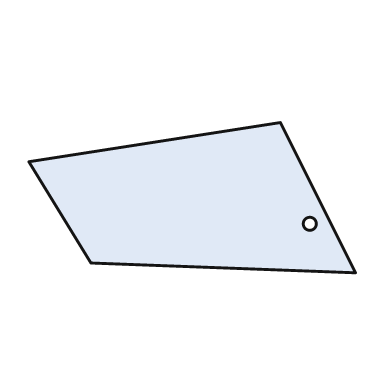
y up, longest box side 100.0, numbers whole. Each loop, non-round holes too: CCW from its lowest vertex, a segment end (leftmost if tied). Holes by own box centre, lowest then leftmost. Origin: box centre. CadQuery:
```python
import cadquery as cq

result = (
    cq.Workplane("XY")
    .moveTo(50.0, -23.0)
    .lineTo(27.0, 23.0)
    .lineTo(-50.0, 11.0)
    .lineTo(-31.0, -20.0)
    .close()
    .moveTo(36.0, -8.0)
    .circle(2.0)
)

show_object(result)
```